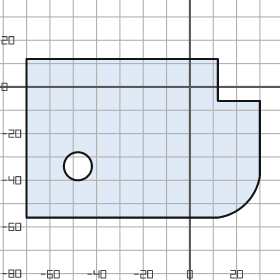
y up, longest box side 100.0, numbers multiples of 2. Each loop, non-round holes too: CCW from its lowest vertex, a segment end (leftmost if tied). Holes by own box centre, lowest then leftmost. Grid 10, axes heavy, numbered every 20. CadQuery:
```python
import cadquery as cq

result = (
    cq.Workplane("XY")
    .moveTo(-70.0, -56.0)
    .lineTo(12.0, -56.0)
    .threePointArc((24.0, -50.0), (30.0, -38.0))
    .lineTo(30.0, -6.0)
    .lineTo(12.0, -6.0)
    .lineTo(12.0, 12.0)
    .lineTo(-70.0, 12.0)
    .close()
    .moveTo(-48.0, -34.0)
    .circle(6.0)
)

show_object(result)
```